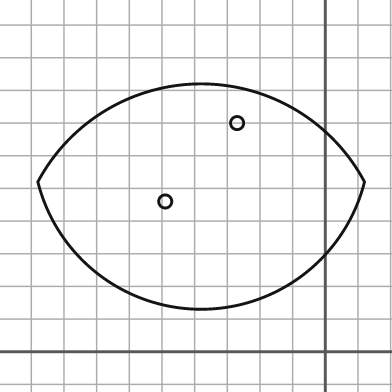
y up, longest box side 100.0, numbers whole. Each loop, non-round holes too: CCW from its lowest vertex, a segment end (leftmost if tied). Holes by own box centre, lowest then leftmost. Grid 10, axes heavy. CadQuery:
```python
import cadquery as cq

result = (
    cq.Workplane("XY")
    .moveTo(-88.0, 52.0)
    .threePointArc((-38.0, 13.0), (12.0, 52.0))
    .threePointArc((-38.0, 82.0), (-88.0, 52.0))
    .close()
    .moveTo(-49.0, 46.0)
    .circle(2.0)
    .moveTo(-27.0, 70.0)
    .circle(2.0)
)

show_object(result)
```